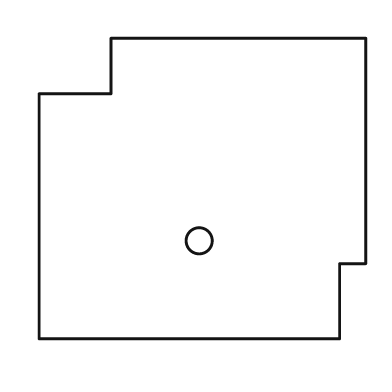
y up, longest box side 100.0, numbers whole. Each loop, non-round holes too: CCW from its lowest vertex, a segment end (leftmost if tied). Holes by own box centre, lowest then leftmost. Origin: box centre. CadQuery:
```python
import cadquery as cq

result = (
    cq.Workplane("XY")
    .moveTo(-50.0, -46.0)
    .lineTo(42.0, -46.0)
    .lineTo(42.0, -23.0)
    .lineTo(50.0, -23.0)
    .lineTo(50.0, 46.0)
    .lineTo(-28.0, 46.0)
    .lineTo(-28.0, 29.0)
    .lineTo(-50.0, 29.0)
    .close()
    .moveTo(-1.0, -16.0)
    .circle(4.0)
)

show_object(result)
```